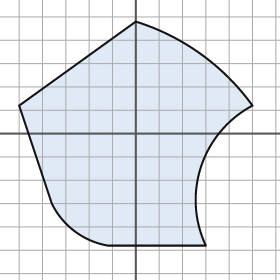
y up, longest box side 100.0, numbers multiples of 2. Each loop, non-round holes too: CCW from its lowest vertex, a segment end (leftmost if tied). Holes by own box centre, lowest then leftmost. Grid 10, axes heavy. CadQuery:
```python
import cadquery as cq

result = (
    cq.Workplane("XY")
    .moveTo(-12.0, -48.0)
    .lineTo(30.0, -48.0)
    .threePointArc((28.0, -14.0), (50.0, 12.0))
    .threePointArc((28.0, 34.0), (0.0, 48.0))
    .lineTo(-50.0, 12.0)
    .lineTo(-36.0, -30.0)
    .threePointArc((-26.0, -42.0), (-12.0, -48.0))
    .close()
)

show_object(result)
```